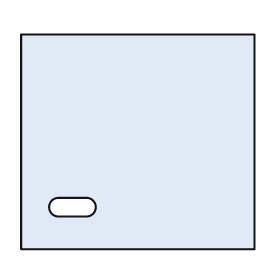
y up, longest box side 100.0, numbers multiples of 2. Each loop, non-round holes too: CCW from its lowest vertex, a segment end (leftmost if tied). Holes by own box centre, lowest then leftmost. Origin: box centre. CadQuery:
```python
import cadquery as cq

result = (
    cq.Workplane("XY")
    .moveTo(-50.0, -46.0)
    .lineTo(50.0, -46.0)
    .lineTo(50.0, 46.0)
    .lineTo(-50.0, 46.0)
    .close()
    .moveTo(-34.0, -32.0)
    .lineTo(-22.0, -32.0)
    .threePointArc((-18.0, -28.0), (-22.0, -24.0))
    .lineTo(-34.0, -24.0)
    .threePointArc((-38.0, -28.0), (-34.0, -32.0))
    .close()
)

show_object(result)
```